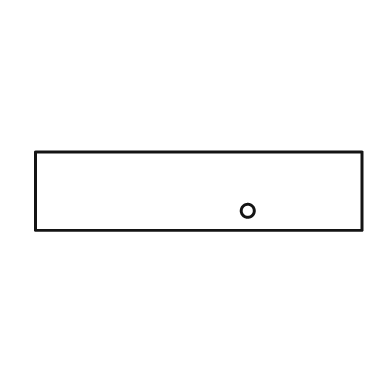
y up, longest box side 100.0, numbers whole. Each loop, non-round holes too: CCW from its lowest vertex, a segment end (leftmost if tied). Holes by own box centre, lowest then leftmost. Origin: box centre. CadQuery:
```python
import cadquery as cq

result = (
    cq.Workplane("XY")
    .moveTo(-50.0, -12.0)
    .lineTo(50.0, -12.0)
    .lineTo(50.0, 12.0)
    .lineTo(-50.0, 12.0)
    .close()
    .moveTo(15.0, -6.0)
    .circle(2.0)
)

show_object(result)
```